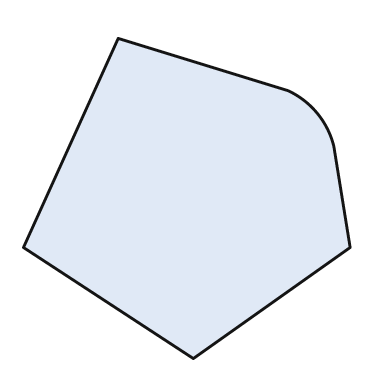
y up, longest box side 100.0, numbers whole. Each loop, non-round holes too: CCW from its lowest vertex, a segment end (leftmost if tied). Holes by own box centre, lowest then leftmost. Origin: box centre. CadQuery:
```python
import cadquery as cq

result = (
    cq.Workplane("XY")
    .moveTo(2.0, -49.0)
    .lineTo(50.0, -15.0)
    .lineTo(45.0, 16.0)
    .threePointArc((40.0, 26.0), (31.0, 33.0))
    .lineTo(-21.0, 49.0)
    .lineTo(-50.0, -15.0)
    .close()
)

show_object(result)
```